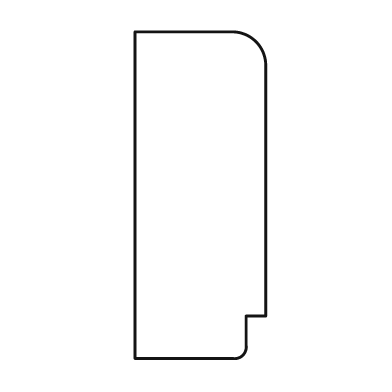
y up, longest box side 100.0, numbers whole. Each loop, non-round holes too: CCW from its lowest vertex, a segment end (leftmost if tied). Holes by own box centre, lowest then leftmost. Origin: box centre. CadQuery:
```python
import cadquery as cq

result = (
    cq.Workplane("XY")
    .moveTo(-20.0, -50.0)
    .lineTo(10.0, -50.0)
    .threePointArc((13.0, -49.0), (14.0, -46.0))
    .lineTo(14.0, -37.0)
    .lineTo(20.0, -37.0)
    .lineTo(20.0, 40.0)
    .threePointArc((17.0, 47.0), (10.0, 50.0))
    .lineTo(-20.0, 50.0)
    .close()
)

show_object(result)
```